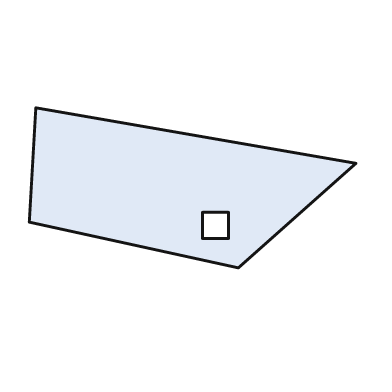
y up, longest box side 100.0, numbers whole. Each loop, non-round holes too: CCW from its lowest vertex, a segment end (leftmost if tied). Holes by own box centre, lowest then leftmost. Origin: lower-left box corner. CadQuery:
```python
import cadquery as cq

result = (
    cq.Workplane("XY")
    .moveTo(64.0, 0.0)
    .lineTo(100.0, 32.0)
    .lineTo(2.0, 49.0)
    .lineTo(0.0, 14.0)
    .close()
    .moveTo(53.0, 9.0)
    .lineTo(61.0, 9.0)
    .lineTo(61.0, 17.0)
    .lineTo(53.0, 17.0)
    .close()
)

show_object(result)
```